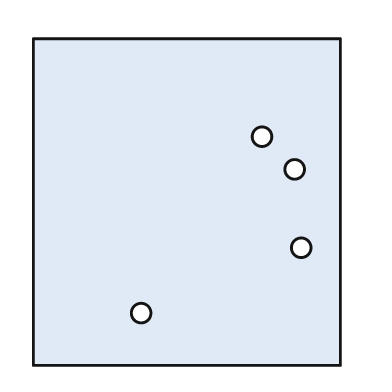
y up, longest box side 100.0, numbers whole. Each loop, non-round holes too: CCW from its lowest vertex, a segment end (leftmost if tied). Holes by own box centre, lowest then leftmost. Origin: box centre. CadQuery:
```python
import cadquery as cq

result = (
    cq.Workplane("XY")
    .moveTo(-47.0, -50.0)
    .lineTo(47.0, -50.0)
    .lineTo(47.0, 50.0)
    .lineTo(-47.0, 50.0)
    .close()
    .moveTo(-14.0, -34.0)
    .circle(3.0)
    .moveTo(35.0, -14.0)
    .circle(3.0)
    .moveTo(33.0, 10.0)
    .circle(3.0)
    .moveTo(23.0, 20.0)
    .circle(3.0)
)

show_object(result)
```